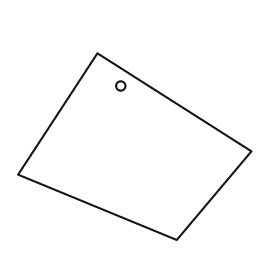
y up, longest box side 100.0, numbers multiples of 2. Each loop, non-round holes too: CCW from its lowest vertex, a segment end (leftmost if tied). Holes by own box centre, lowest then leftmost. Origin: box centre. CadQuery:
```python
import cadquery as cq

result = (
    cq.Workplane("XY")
    .moveTo(18.0, -40.0)
    .lineTo(50.0, -2.0)
    .lineTo(-16.0, 40.0)
    .lineTo(-50.0, -12.0)
    .close()
    .moveTo(-6.0, 26.0)
    .circle(2.0)
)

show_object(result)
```